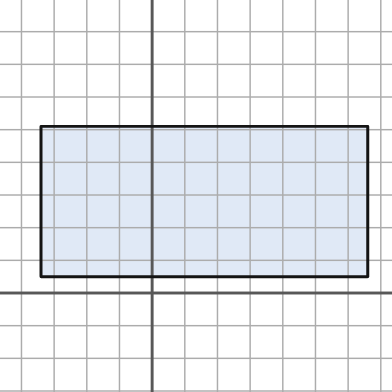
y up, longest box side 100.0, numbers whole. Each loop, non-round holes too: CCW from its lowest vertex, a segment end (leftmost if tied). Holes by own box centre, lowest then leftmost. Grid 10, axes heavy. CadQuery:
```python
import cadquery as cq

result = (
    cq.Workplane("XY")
    .moveTo(-34.0, 5.0)
    .lineTo(66.0, 5.0)
    .lineTo(66.0, 51.0)
    .lineTo(-34.0, 51.0)
    .close()
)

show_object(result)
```